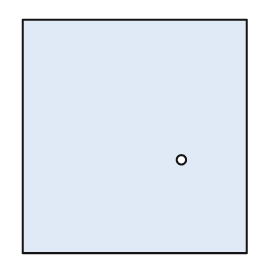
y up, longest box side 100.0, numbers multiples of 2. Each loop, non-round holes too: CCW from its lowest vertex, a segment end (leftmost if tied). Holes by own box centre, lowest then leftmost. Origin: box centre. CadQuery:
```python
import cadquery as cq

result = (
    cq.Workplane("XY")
    .moveTo(-48.0, -50.0)
    .lineTo(48.0, -50.0)
    .lineTo(48.0, 50.0)
    .lineTo(-48.0, 50.0)
    .close()
    .moveTo(20.0, -10.0)
    .circle(2.0)
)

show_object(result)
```